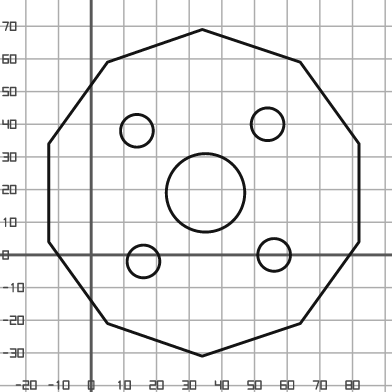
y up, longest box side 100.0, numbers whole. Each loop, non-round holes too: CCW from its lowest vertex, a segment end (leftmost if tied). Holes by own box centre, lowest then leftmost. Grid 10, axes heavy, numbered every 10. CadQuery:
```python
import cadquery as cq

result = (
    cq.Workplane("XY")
    .moveTo(34.0, -31.0)
    .lineTo(64.0, -21.0)
    .lineTo(82.0, 4.0)
    .lineTo(82.0, 34.0)
    .lineTo(64.0, 59.0)
    .lineTo(34.0, 69.0)
    .lineTo(5.0, 59.0)
    .lineTo(-13.0, 34.0)
    .lineTo(-13.0, 4.0)
    .lineTo(5.0, -21.0)
    .close()
    .moveTo(16.0, -2.0)
    .circle(5.0)
    .moveTo(56.0, 0.0)
    .circle(5.0)
    .moveTo(35.0, 19.0)
    .circle(12.0)
    .moveTo(14.0, 38.0)
    .circle(5.0)
    .moveTo(54.0, 40.0)
    .circle(5.0)
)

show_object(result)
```